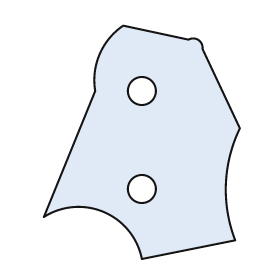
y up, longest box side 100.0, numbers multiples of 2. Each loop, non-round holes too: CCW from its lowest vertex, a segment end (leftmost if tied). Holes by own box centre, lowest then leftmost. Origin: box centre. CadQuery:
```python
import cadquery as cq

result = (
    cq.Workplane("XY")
    .moveTo(0.0, -50.0)
    .lineTo(40.0, -42.0)
    .threePointArc((36.0, -18.0), (42.0, 6.0))
    .lineTo(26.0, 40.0)
    .threePointArc((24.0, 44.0), (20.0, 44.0))
    .lineTo(-8.0, 50.0)
    .threePointArc((-18.0, 38.0), (-20.0, 22.0))
    .lineTo(-42.0, -32.0)
    .threePointArc((-16.0, -30.0), (0.0, -50.0))
    .close()
    .moveTo(0.0, -20.0)
    .circle(6.0)
    .moveTo(0.0, 22.0)
    .circle(6.0)
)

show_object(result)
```